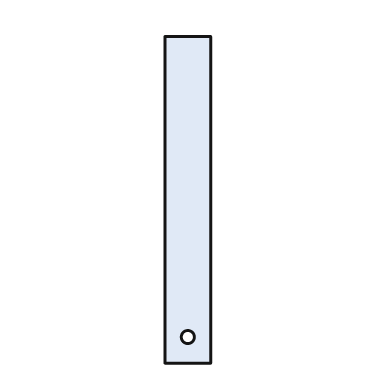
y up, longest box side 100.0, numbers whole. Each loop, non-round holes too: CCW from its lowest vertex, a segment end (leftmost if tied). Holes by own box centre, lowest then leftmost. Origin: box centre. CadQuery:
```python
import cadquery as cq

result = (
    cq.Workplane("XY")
    .moveTo(-7.0, -50.0)
    .lineTo(7.0, -50.0)
    .lineTo(7.0, 50.0)
    .lineTo(-7.0, 50.0)
    .close()
    .moveTo(0.0, -42.0)
    .circle(2.0)
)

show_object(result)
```